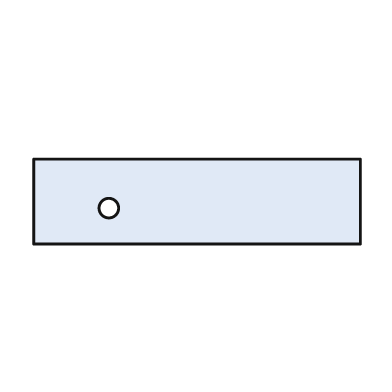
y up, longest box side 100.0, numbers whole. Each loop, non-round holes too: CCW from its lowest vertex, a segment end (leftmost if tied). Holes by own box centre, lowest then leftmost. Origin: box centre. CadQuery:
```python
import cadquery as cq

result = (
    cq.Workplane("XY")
    .moveTo(-50.0, -13.0)
    .lineTo(50.0, -13.0)
    .lineTo(50.0, 13.0)
    .lineTo(-50.0, 13.0)
    .close()
    .moveTo(-27.0, -2.0)
    .circle(3.0)
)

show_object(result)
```